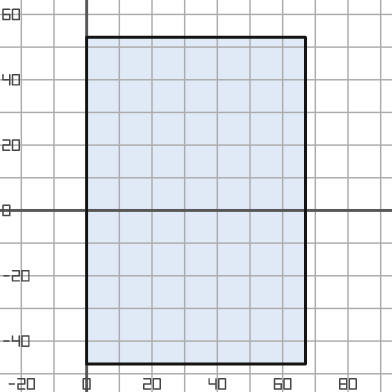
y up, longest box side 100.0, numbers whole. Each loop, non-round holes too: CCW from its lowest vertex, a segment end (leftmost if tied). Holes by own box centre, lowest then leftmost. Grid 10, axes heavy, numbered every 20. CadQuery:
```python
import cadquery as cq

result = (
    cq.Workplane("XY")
    .moveTo(0.0, -47.0)
    .lineTo(67.0, -47.0)
    .lineTo(67.0, 53.0)
    .lineTo(0.0, 53.0)
    .close()
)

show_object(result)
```